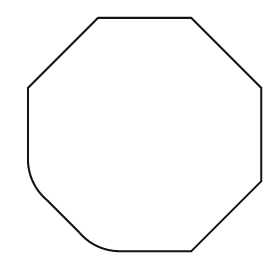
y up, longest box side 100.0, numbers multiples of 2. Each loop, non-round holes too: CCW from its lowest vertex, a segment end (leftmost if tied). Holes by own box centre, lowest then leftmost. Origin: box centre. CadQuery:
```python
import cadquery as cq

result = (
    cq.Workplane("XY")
    .moveTo(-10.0, -50.0)
    .lineTo(20.0, -50.0)
    .lineTo(50.0, -20.0)
    .lineTo(50.0, 20.0)
    .lineTo(20.0, 50.0)
    .lineTo(-20.0, 50.0)
    .lineTo(-50.0, 20.0)
    .lineTo(-50.0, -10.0)
    .threePointArc((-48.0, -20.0), (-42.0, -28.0))
    .lineTo(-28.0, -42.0)
    .threePointArc((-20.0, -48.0), (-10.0, -50.0))
    .close()
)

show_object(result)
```